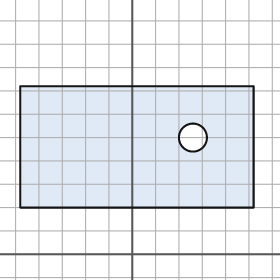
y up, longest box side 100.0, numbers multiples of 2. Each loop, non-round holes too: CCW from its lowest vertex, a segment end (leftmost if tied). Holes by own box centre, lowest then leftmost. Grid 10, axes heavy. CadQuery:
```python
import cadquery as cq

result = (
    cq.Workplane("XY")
    .moveTo(-48.0, 20.0)
    .lineTo(52.0, 20.0)
    .lineTo(52.0, 72.0)
    .lineTo(-48.0, 72.0)
    .close()
    .moveTo(26.0, 50.0)
    .circle(6.0)
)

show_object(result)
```